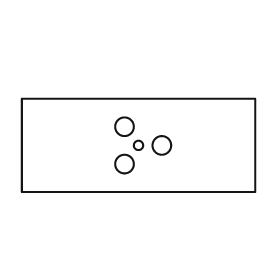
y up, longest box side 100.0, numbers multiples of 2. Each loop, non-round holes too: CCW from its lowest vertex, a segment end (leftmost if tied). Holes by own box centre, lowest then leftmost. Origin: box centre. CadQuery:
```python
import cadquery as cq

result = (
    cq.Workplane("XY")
    .moveTo(-50.0, -20.0)
    .lineTo(50.0, -20.0)
    .lineTo(50.0, 20.0)
    .lineTo(-50.0, 20.0)
    .close()
    .moveTo(-6.0, -8.0)
    .circle(4.0)
    .moveTo(0.0, 0.0)
    .circle(2.0)
    .moveTo(10.0, 0.0)
    .circle(4.0)
    .moveTo(-6.0, 8.0)
    .circle(4.0)
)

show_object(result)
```